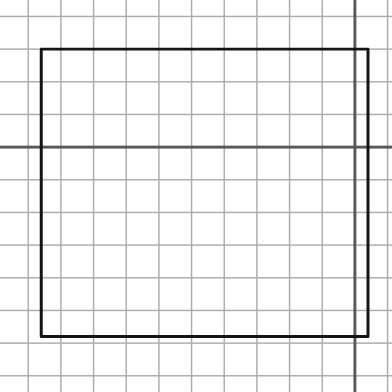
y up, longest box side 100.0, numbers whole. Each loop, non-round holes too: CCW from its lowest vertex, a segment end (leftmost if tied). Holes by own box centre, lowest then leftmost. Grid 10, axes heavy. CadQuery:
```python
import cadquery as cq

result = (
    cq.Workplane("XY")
    .moveTo(-96.0, -58.0)
    .lineTo(4.0, -58.0)
    .lineTo(4.0, 30.0)
    .lineTo(-96.0, 30.0)
    .close()
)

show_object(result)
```